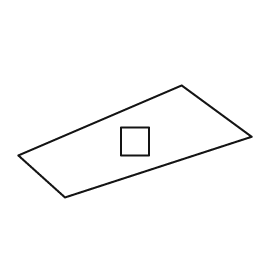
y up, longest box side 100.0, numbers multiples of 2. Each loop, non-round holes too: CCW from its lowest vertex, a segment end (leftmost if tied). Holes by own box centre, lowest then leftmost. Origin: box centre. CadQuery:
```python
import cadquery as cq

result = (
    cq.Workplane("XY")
    .moveTo(-30.0, -24.0)
    .lineTo(50.0, 2.0)
    .lineTo(20.0, 24.0)
    .lineTo(-50.0, -6.0)
    .close()
    .moveTo(-6.0, -6.0)
    .lineTo(6.0, -6.0)
    .lineTo(6.0, 6.0)
    .lineTo(-6.0, 6.0)
    .close()
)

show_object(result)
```